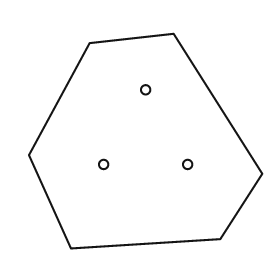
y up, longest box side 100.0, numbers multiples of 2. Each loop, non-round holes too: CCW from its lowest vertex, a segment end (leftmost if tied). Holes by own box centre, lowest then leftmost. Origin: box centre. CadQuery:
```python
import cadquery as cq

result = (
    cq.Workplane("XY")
    .moveTo(-32.0, -46.0)
    .lineTo(32.0, -42.0)
    .lineTo(50.0, -14.0)
    .lineTo(12.0, 46.0)
    .lineTo(-24.0, 42.0)
    .lineTo(-50.0, -6.0)
    .close()
    .moveTo(-18.0, -10.0)
    .circle(2.0)
    .moveTo(18.0, -10.0)
    .circle(2.0)
    .moveTo(0.0, 22.0)
    .circle(2.0)
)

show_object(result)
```